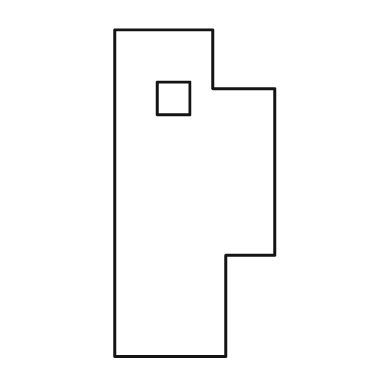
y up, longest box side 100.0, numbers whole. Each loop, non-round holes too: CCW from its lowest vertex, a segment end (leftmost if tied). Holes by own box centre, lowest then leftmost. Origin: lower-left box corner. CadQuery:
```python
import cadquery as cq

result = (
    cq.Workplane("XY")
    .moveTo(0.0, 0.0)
    .lineTo(34.0, 0.0)
    .lineTo(34.0, 31.0)
    .lineTo(49.0, 31.0)
    .lineTo(49.0, 82.0)
    .lineTo(30.0, 82.0)
    .lineTo(30.0, 100.0)
    .lineTo(0.0, 100.0)
    .close()
    .moveTo(13.0, 74.0)
    .lineTo(23.0, 74.0)
    .lineTo(23.0, 84.0)
    .lineTo(13.0, 84.0)
    .close()
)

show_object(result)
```